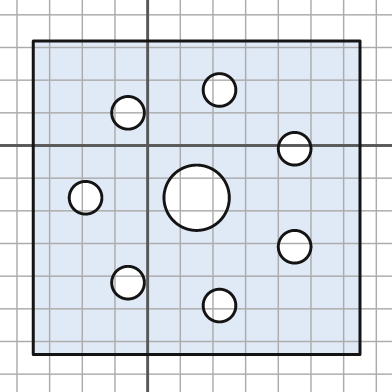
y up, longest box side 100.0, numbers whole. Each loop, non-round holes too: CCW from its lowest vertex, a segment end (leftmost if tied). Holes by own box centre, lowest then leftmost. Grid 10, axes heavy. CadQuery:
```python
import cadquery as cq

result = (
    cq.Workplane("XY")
    .moveTo(-35.0, -64.0)
    .lineTo(65.0, -64.0)
    .lineTo(65.0, 32.0)
    .lineTo(-35.0, 32.0)
    .close()
    .moveTo(22.0, -49.0)
    .circle(5.0)
    .moveTo(-6.0, -42.0)
    .circle(5.0)
    .moveTo(45.0, -31.0)
    .circle(5.0)
    .moveTo(-19.0, -16.0)
    .circle(5.0)
    .moveTo(15.0, -16.0)
    .circle(10.0)
    .moveTo(45.0, -1.0)
    .circle(5.0)
    .moveTo(-6.0, 10.0)
    .circle(5.0)
    .moveTo(22.0, 17.0)
    .circle(5.0)
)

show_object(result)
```